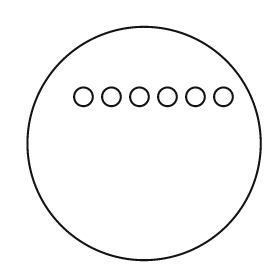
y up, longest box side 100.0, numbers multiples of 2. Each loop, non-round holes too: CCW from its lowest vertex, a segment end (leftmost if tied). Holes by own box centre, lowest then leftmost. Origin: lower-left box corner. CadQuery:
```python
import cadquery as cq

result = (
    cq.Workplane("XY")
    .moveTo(50.0, 50.0)
    .circle(50.0)
    .moveTo(24.0, 70.0)
    .circle(4.0)
    .moveTo(36.0, 70.0)
    .circle(4.0)
    .moveTo(48.0, 70.0)
    .circle(4.0)
    .moveTo(60.0, 70.0)
    .circle(4.0)
    .moveTo(72.0, 70.0)
    .circle(4.0)
    .moveTo(84.0, 70.0)
    .circle(4.0)
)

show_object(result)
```